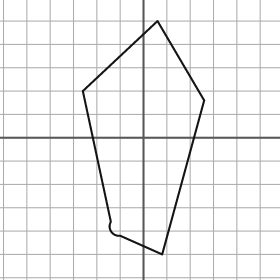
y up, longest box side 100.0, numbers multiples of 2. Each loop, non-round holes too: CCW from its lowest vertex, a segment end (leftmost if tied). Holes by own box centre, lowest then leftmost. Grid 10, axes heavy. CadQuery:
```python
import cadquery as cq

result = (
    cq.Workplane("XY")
    .moveTo(8.0, -50.0)
    .lineTo(26.0, 16.0)
    .lineTo(6.0, 50.0)
    .lineTo(-26.0, 20.0)
    .lineTo(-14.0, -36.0)
    .threePointArc((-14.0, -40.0), (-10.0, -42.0))
    .close()
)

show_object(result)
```